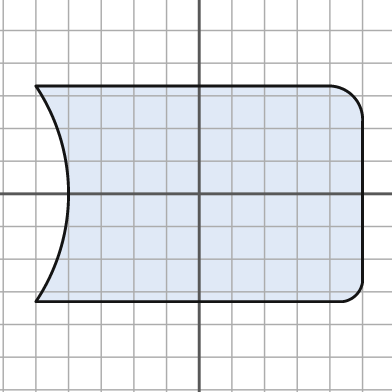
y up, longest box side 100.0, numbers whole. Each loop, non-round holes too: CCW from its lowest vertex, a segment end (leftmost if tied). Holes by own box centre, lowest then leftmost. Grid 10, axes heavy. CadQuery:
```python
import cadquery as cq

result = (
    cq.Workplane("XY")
    .moveTo(-50.0, -33.0)
    .lineTo(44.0, -33.0)
    .threePointArc((48.0, -31.0), (50.0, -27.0))
    .lineTo(50.0, 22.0)
    .threePointArc((47.0, 30.0), (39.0, 33.0))
    .lineTo(-50.0, 33.0)
    .threePointArc((-40.0, 0.0), (-50.0, -33.0))
    .close()
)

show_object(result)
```